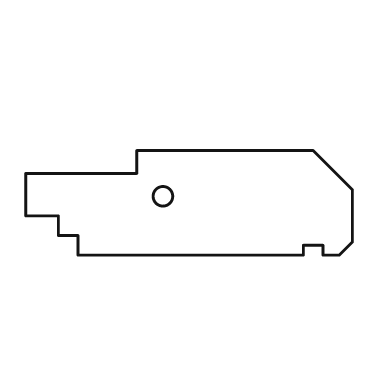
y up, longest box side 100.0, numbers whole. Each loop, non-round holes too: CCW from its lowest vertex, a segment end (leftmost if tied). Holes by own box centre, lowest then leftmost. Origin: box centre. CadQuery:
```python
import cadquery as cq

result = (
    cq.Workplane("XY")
    .moveTo(-34.0, -16.0)
    .lineTo(35.0, -16.0)
    .lineTo(35.0, -13.0)
    .lineTo(41.0, -13.0)
    .lineTo(41.0, -16.0)
    .lineTo(46.0, -16.0)
    .lineTo(50.0, -12.0)
    .lineTo(50.0, 4.0)
    .lineTo(38.0, 16.0)
    .lineTo(-16.0, 16.0)
    .lineTo(-16.0, 9.0)
    .lineTo(-50.0, 9.0)
    .lineTo(-50.0, -4.0)
    .lineTo(-40.0, -4.0)
    .lineTo(-40.0, -10.0)
    .lineTo(-34.0, -10.0)
    .close()
    .moveTo(-8.0, 2.0)
    .circle(3.0)
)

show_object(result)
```